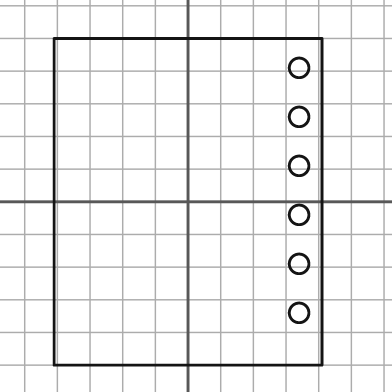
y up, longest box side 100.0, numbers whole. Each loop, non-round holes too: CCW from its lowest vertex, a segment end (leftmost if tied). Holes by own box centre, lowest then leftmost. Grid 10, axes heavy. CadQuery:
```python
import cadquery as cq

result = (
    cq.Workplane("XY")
    .moveTo(-41.0, -50.0)
    .lineTo(41.0, -50.0)
    .lineTo(41.0, 50.0)
    .lineTo(-41.0, 50.0)
    .close()
    .moveTo(34.0, -34.0)
    .circle(3.0)
    .moveTo(34.0, -19.0)
    .circle(3.0)
    .moveTo(34.0, -4.0)
    .circle(3.0)
    .moveTo(34.0, 11.0)
    .circle(3.0)
    .moveTo(34.0, 26.0)
    .circle(3.0)
    .moveTo(34.0, 41.0)
    .circle(3.0)
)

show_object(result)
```